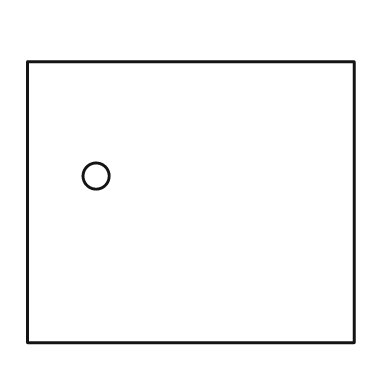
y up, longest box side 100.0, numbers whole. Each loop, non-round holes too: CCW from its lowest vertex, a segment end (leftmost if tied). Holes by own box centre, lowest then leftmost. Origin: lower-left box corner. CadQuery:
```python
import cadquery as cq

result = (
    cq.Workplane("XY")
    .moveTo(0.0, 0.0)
    .lineTo(100.0, 0.0)
    .lineTo(100.0, 86.0)
    .lineTo(0.0, 86.0)
    .close()
    .moveTo(21.0, 51.0)
    .circle(4.0)
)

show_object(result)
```